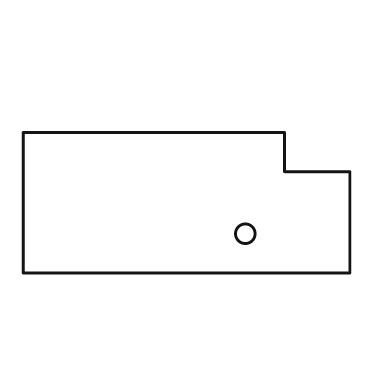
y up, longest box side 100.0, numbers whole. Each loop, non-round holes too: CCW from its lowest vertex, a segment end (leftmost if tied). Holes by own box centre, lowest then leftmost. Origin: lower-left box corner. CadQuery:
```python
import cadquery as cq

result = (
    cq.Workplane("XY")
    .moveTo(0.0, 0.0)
    .lineTo(100.0, 0.0)
    .lineTo(100.0, 31.0)
    .lineTo(80.0, 31.0)
    .lineTo(80.0, 43.0)
    .lineTo(0.0, 43.0)
    .close()
    .moveTo(68.0, 12.0)
    .circle(3.0)
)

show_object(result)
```